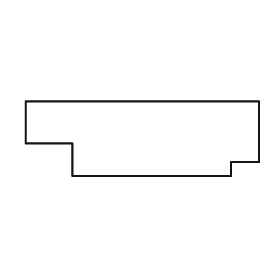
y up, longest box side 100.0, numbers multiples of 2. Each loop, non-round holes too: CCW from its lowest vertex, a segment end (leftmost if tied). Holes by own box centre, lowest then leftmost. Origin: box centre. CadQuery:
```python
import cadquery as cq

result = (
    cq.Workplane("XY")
    .moveTo(-30.0, -16.0)
    .lineTo(38.0, -16.0)
    .lineTo(38.0, -10.0)
    .lineTo(50.0, -10.0)
    .lineTo(50.0, 16.0)
    .lineTo(-50.0, 16.0)
    .lineTo(-50.0, -2.0)
    .lineTo(-30.0, -2.0)
    .close()
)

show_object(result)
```